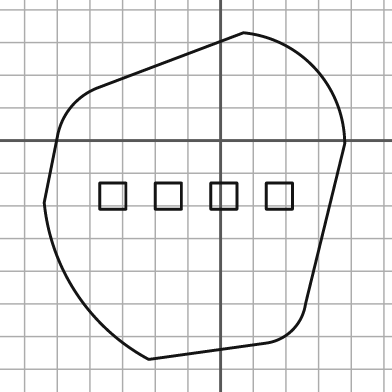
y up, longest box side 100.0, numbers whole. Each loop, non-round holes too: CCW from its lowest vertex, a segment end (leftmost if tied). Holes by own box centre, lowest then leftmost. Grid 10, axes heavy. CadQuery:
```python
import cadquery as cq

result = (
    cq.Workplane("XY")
    .moveTo(-22.0, -67.0)
    .lineTo(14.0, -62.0)
    .threePointArc((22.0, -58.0), (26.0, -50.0))
    .lineTo(38.0, -1.0)
    .threePointArc((29.0, 22.0), (7.0, 33.0))
    .lineTo(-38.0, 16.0)
    .threePointArc((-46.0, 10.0), (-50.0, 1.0))
    .lineTo(-54.0, -19.0)
    .threePointArc((-44.0, -47.0), (-22.0, -67.0))
    .close()
    .moveTo(-37.0, -21.0)
    .lineTo(-29.0, -21.0)
    .lineTo(-29.0, -13.0)
    .lineTo(-37.0, -13.0)
    .close()
    .moveTo(-20.0, -21.0)
    .lineTo(-12.0, -21.0)
    .lineTo(-12.0, -13.0)
    .lineTo(-20.0, -13.0)
    .close()
    .moveTo(-3.0, -21.0)
    .lineTo(5.0, -21.0)
    .lineTo(5.0, -13.0)
    .lineTo(-3.0, -13.0)
    .close()
    .moveTo(14.0, -21.0)
    .lineTo(22.0, -21.0)
    .lineTo(22.0, -13.0)
    .lineTo(14.0, -13.0)
    .close()
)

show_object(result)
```